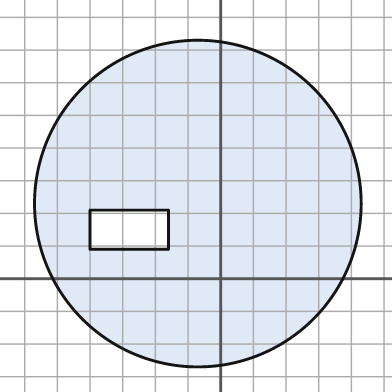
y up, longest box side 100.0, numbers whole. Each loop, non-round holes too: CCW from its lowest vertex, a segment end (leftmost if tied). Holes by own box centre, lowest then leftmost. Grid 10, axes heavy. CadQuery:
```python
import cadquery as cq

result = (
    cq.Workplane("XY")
    .moveTo(-7.0, 23.0)
    .circle(50.0)
    .moveTo(-40.0, 9.0)
    .lineTo(-16.0, 9.0)
    .lineTo(-16.0, 21.0)
    .lineTo(-40.0, 21.0)
    .close()
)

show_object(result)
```